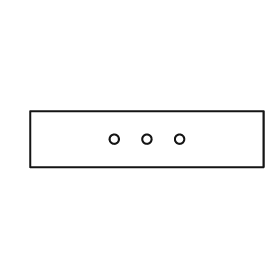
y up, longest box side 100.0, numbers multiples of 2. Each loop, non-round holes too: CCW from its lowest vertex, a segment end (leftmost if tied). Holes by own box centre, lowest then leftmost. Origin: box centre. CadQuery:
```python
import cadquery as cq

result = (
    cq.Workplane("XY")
    .moveTo(-50.0, -12.0)
    .lineTo(50.0, -12.0)
    .lineTo(50.0, 12.0)
    .lineTo(-50.0, 12.0)
    .close()
    .moveTo(-14.0, 0.0)
    .circle(2.0)
    .moveTo(0.0, 0.0)
    .circle(2.0)
    .moveTo(14.0, 0.0)
    .circle(2.0)
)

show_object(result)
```